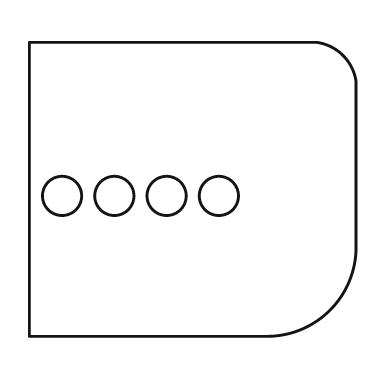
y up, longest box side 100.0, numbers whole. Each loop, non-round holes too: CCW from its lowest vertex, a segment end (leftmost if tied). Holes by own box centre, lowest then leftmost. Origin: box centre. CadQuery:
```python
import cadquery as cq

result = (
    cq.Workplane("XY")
    .moveTo(-50.0, -45.0)
    .lineTo(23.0, -45.0)
    .threePointArc((42.0, -37.0), (50.0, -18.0))
    .lineTo(50.0, 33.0)
    .threePointArc((46.0, 41.0), (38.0, 45.0))
    .lineTo(-50.0, 45.0)
    .close()
    .moveTo(-40.0, -2.0)
    .circle(6.0)
    .moveTo(-24.0, -2.0)
    .circle(6.0)
    .moveTo(-8.0, -2.0)
    .circle(6.0)
    .moveTo(8.0, -2.0)
    .circle(6.0)
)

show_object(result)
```